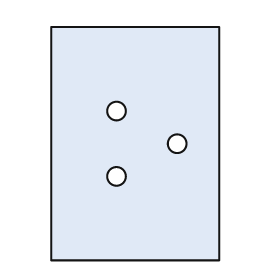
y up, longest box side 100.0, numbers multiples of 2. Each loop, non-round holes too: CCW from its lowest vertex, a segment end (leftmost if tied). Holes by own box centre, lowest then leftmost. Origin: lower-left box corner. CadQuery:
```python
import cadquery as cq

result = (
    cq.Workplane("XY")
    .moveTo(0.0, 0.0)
    .lineTo(72.0, 0.0)
    .lineTo(72.0, 100.0)
    .lineTo(0.0, 100.0)
    .close()
    .moveTo(28.0, 36.0)
    .circle(4.0)
    .moveTo(54.0, 50.0)
    .circle(4.0)
    .moveTo(28.0, 64.0)
    .circle(4.0)
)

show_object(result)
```